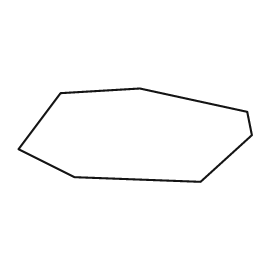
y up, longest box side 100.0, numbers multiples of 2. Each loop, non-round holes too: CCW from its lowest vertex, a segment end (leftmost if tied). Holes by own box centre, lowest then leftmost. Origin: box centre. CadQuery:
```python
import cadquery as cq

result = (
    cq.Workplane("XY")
    .moveTo(28.0, -20.0)
    .lineTo(50.0, 0.0)
    .lineTo(48.0, 10.0)
    .lineTo(2.0, 20.0)
    .lineTo(-32.0, 18.0)
    .lineTo(-50.0, -6.0)
    .lineTo(-26.0, -18.0)
    .close()
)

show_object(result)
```